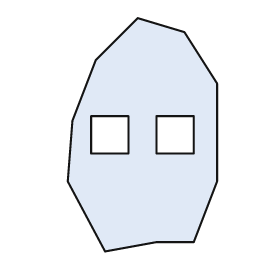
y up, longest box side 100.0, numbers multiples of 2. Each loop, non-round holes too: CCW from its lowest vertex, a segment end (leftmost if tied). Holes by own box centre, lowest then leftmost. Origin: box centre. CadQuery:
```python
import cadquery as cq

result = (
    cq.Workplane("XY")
    .moveTo(-16.0, -50.0)
    .lineTo(6.0, -46.0)
    .lineTo(22.0, -46.0)
    .lineTo(32.0, -20.0)
    .lineTo(32.0, 22.0)
    .lineTo(18.0, 44.0)
    .lineTo(-2.0, 50.0)
    .lineTo(-20.0, 32.0)
    .lineTo(-30.0, 6.0)
    .lineTo(-32.0, -20.0)
    .close()
    .moveTo(-22.0, -8.0)
    .lineTo(-6.0, -8.0)
    .lineTo(-6.0, 8.0)
    .lineTo(-22.0, 8.0)
    .close()
    .moveTo(6.0, -8.0)
    .lineTo(22.0, -8.0)
    .lineTo(22.0, 8.0)
    .lineTo(6.0, 8.0)
    .close()
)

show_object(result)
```